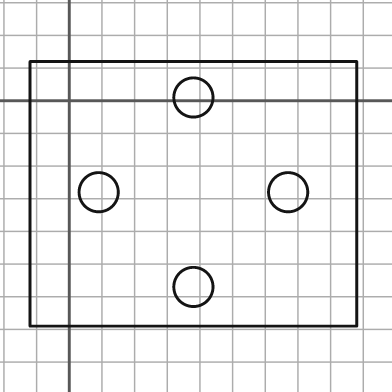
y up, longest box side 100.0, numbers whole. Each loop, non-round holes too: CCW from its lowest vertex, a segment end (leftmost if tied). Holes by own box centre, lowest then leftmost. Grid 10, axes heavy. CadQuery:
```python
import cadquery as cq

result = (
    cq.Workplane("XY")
    .moveTo(-12.0, -69.0)
    .lineTo(88.0, -69.0)
    .lineTo(88.0, 12.0)
    .lineTo(-12.0, 12.0)
    .close()
    .moveTo(38.0, -57.0)
    .circle(6.0)
    .moveTo(9.0, -28.0)
    .circle(6.0)
    .moveTo(67.0, -28.0)
    .circle(6.0)
    .moveTo(38.0, 1.0)
    .circle(6.0)
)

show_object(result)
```